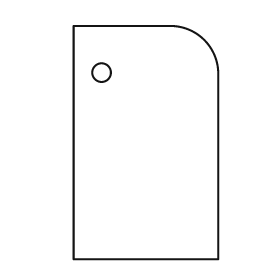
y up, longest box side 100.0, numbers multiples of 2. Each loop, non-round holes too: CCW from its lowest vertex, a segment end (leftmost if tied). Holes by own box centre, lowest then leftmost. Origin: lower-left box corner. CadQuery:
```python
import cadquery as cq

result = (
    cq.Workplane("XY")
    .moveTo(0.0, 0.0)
    .lineTo(62.0, 0.0)
    .lineTo(62.0, 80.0)
    .threePointArc((56.0, 94.0), (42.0, 100.0))
    .lineTo(0.0, 100.0)
    .close()
    .moveTo(12.0, 80.0)
    .circle(4.0)
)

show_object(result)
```